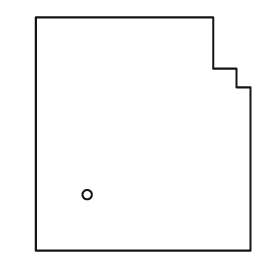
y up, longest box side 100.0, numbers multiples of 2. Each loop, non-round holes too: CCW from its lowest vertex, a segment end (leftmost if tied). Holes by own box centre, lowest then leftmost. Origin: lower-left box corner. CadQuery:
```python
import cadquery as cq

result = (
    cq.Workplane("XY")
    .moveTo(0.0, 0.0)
    .lineTo(92.0, 0.0)
    .lineTo(92.0, 70.0)
    .lineTo(86.0, 70.0)
    .lineTo(86.0, 78.0)
    .lineTo(76.0, 78.0)
    .lineTo(76.0, 100.0)
    .lineTo(0.0, 100.0)
    .close()
    .moveTo(22.0, 24.0)
    .circle(2.0)
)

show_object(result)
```